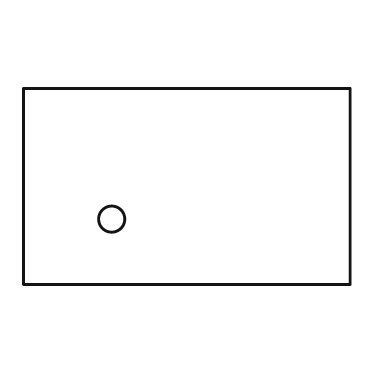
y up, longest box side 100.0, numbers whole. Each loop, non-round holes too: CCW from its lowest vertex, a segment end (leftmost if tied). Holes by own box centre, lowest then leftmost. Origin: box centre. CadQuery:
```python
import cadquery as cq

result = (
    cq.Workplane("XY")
    .moveTo(-50.0, -30.0)
    .lineTo(50.0, -30.0)
    .lineTo(50.0, 30.0)
    .lineTo(-50.0, 30.0)
    .close()
    .moveTo(-23.0, -10.0)
    .circle(4.0)
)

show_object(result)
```